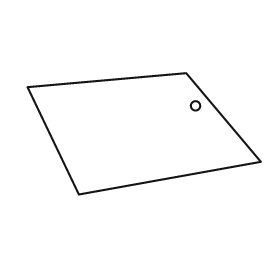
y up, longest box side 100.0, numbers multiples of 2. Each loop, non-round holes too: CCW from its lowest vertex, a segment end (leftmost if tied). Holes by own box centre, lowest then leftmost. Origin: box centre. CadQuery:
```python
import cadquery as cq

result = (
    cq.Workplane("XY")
    .moveTo(-28.0, -26.0)
    .lineTo(50.0, -12.0)
    .lineTo(18.0, 26.0)
    .lineTo(-50.0, 20.0)
    .close()
    .moveTo(22.0, 12.0)
    .circle(2.0)
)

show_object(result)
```